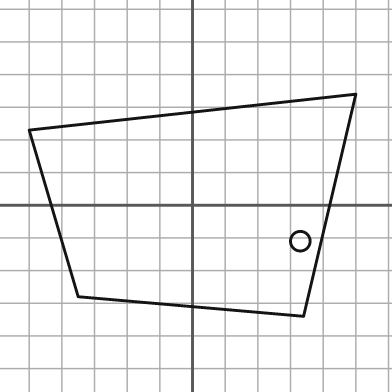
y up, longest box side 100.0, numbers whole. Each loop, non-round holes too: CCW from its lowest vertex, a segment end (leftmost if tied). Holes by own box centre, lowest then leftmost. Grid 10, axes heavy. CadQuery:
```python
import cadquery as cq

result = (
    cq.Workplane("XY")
    .moveTo(34.0, -34.0)
    .lineTo(50.0, 34.0)
    .lineTo(-50.0, 23.0)
    .lineTo(-35.0, -28.0)
    .close()
    .moveTo(33.0, -11.0)
    .circle(3.0)
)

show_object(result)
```